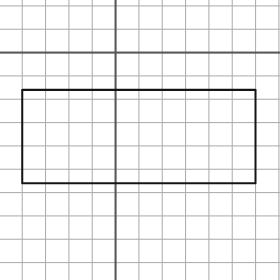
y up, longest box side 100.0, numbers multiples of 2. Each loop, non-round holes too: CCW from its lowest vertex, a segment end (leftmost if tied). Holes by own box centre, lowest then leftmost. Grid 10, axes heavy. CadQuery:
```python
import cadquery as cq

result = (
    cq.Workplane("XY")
    .moveTo(-40.0, -56.0)
    .lineTo(60.0, -56.0)
    .lineTo(60.0, -16.0)
    .lineTo(-40.0, -16.0)
    .close()
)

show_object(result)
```